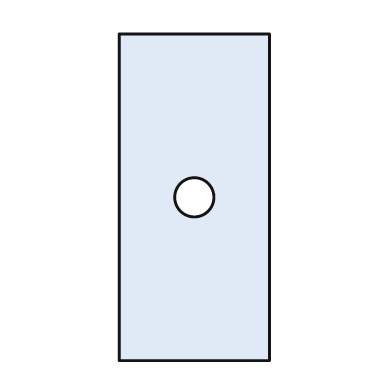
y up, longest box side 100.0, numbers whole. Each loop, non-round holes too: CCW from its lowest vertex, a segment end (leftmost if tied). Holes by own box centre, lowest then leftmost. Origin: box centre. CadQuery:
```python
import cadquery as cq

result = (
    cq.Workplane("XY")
    .moveTo(-23.0, -50.0)
    .lineTo(23.0, -50.0)
    .lineTo(23.0, 50.0)
    .lineTo(-23.0, 50.0)
    .close()
    .moveTo(0.0, 0.0)
    .circle(6.0)
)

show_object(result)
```